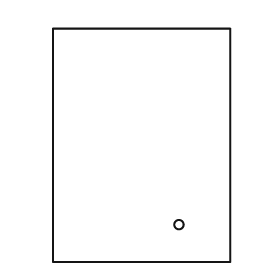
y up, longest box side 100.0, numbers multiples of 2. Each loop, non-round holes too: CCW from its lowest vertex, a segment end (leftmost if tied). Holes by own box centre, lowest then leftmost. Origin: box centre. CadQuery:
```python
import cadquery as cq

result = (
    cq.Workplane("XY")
    .moveTo(-38.0, -50.0)
    .lineTo(38.0, -50.0)
    .lineTo(38.0, 50.0)
    .lineTo(-38.0, 50.0)
    .close()
    .moveTo(16.0, -34.0)
    .circle(2.0)
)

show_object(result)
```